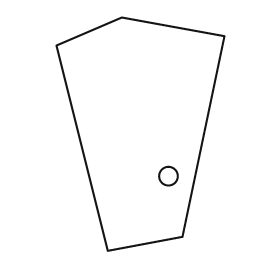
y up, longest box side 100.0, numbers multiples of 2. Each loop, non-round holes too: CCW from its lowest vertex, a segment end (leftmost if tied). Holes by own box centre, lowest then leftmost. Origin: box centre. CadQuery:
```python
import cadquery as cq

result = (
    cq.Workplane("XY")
    .moveTo(-14.0, -50.0)
    .lineTo(18.0, -44.0)
    .lineTo(36.0, 42.0)
    .lineTo(-8.0, 50.0)
    .lineTo(-36.0, 38.0)
    .close()
    .moveTo(12.0, -18.0)
    .circle(4.0)
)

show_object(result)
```